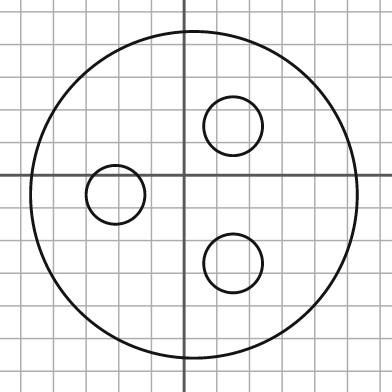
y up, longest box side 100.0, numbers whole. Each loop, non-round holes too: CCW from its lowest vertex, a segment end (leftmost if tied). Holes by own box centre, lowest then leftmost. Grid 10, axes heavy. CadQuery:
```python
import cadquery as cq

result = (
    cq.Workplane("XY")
    .moveTo(3.0, -6.0)
    .circle(50.0)
    .moveTo(15.0, -27.0)
    .circle(9.0)
    .moveTo(-21.0, -6.0)
    .circle(9.0)
    .moveTo(15.0, 15.0)
    .circle(9.0)
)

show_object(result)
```